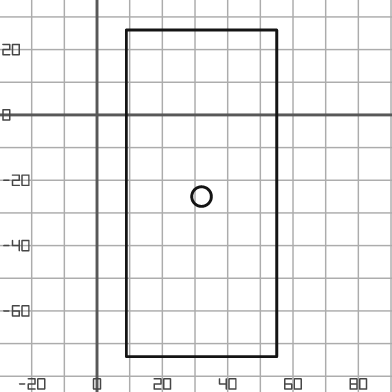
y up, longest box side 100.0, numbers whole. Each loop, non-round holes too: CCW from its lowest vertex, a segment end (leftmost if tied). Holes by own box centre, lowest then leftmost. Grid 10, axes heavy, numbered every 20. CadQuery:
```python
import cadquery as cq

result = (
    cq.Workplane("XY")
    .moveTo(9.0, -74.0)
    .lineTo(55.0, -74.0)
    .lineTo(55.0, 26.0)
    .lineTo(9.0, 26.0)
    .close()
    .moveTo(32.0, -25.0)
    .circle(3.0)
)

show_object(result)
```